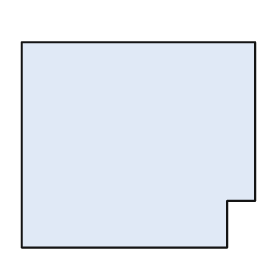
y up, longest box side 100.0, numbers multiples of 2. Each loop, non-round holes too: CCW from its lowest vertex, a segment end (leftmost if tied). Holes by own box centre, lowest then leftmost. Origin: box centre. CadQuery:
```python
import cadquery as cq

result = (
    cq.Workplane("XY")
    .moveTo(-50.0, -44.0)
    .lineTo(38.0, -44.0)
    .lineTo(38.0, -24.0)
    .lineTo(50.0, -24.0)
    .lineTo(50.0, 44.0)
    .lineTo(-50.0, 44.0)
    .close()
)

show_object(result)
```